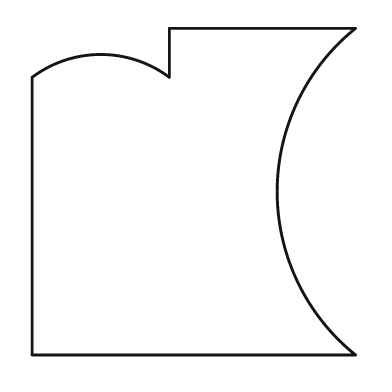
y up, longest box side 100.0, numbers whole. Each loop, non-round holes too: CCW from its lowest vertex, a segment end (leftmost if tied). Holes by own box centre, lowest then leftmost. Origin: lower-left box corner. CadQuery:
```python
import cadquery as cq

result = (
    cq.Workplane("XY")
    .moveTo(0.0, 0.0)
    .lineTo(99.0, 0.0)
    .threePointArc((75.0, 50.0), (99.0, 100.0))
    .lineTo(42.0, 100.0)
    .lineTo(42.0, 85.0)
    .threePointArc((21.0, 92.0), (0.0, 85.0))
    .close()
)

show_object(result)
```